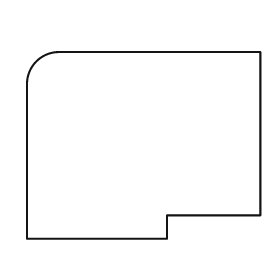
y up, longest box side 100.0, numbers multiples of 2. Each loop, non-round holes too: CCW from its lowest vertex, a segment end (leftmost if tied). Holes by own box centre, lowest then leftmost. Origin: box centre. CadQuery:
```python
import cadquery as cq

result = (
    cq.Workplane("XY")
    .moveTo(-50.0, -40.0)
    .lineTo(10.0, -40.0)
    .lineTo(10.0, -30.0)
    .lineTo(50.0, -30.0)
    .lineTo(50.0, 40.0)
    .lineTo(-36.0, 40.0)
    .threePointArc((-46.0, 36.0), (-50.0, 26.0))
    .close()
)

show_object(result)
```